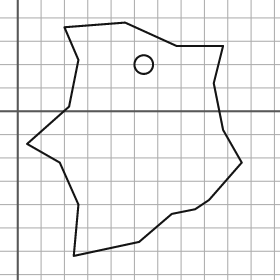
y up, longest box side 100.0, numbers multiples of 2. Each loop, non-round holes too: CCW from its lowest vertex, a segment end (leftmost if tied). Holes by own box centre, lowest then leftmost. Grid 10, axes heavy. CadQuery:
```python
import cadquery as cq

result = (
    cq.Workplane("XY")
    .moveTo(24.0, -62.0)
    .lineTo(52.0, -56.0)
    .lineTo(66.0, -44.0)
    .lineTo(76.0, -42.0)
    .lineTo(82.0, -38.0)
    .lineTo(96.0, -22.0)
    .lineTo(88.0, -8.0)
    .lineTo(84.0, 12.0)
    .lineTo(88.0, 28.0)
    .lineTo(68.0, 28.0)
    .lineTo(46.0, 38.0)
    .lineTo(20.0, 36.0)
    .lineTo(26.0, 22.0)
    .lineTo(22.0, 2.0)
    .lineTo(4.0, -14.0)
    .lineTo(18.0, -22.0)
    .lineTo(26.0, -40.0)
    .close()
    .moveTo(54.0, 20.0)
    .circle(4.0)
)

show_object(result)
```